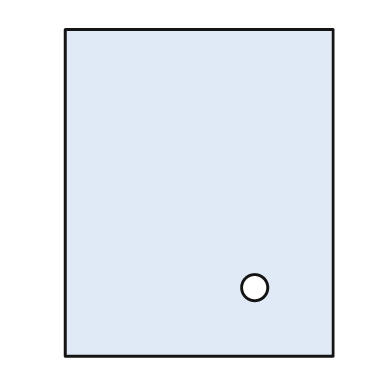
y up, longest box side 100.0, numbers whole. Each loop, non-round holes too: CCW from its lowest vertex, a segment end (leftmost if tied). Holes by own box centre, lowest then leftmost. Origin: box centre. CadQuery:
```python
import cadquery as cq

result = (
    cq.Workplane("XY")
    .moveTo(-41.0, -50.0)
    .lineTo(41.0, -50.0)
    .lineTo(41.0, 50.0)
    .lineTo(-41.0, 50.0)
    .close()
    .moveTo(17.0, -29.0)
    .circle(4.0)
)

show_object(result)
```